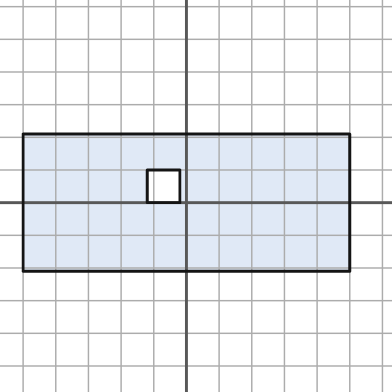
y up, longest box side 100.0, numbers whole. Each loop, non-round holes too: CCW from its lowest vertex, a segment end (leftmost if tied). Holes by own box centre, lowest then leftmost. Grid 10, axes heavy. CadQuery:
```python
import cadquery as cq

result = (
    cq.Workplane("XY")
    .moveTo(-50.0, -21.0)
    .lineTo(50.0, -21.0)
    .lineTo(50.0, 21.0)
    .lineTo(-50.0, 21.0)
    .close()
    .moveTo(-12.0, 0.0)
    .lineTo(-2.0, 0.0)
    .lineTo(-2.0, 10.0)
    .lineTo(-12.0, 10.0)
    .close()
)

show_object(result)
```